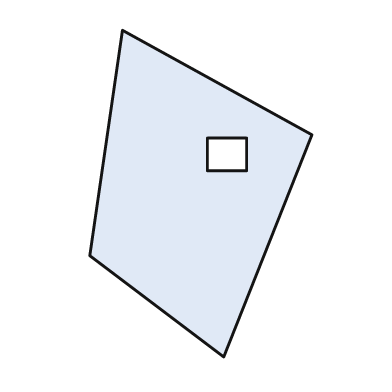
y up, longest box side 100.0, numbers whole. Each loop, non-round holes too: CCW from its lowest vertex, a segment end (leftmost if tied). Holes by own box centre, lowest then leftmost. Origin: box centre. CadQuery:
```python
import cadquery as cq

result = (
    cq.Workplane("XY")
    .moveTo(7.0, -50.0)
    .lineTo(34.0, 18.0)
    .lineTo(-24.0, 50.0)
    .lineTo(-34.0, -19.0)
    .close()
    .moveTo(2.0, 7.0)
    .lineTo(14.0, 7.0)
    .lineTo(14.0, 17.0)
    .lineTo(2.0, 17.0)
    .close()
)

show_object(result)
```